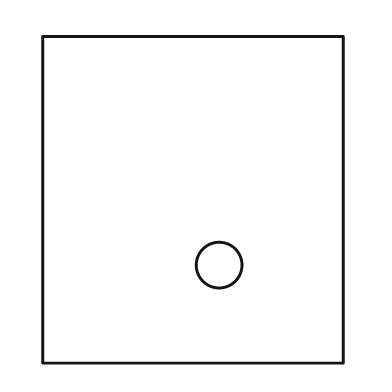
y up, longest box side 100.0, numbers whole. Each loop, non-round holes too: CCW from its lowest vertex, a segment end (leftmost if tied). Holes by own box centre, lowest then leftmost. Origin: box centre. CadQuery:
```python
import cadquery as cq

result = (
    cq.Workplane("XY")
    .moveTo(-46.0, -50.0)
    .lineTo(46.0, -50.0)
    .lineTo(46.0, 50.0)
    .lineTo(-46.0, 50.0)
    .close()
    .moveTo(8.0, -20.0)
    .circle(7.0)
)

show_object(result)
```